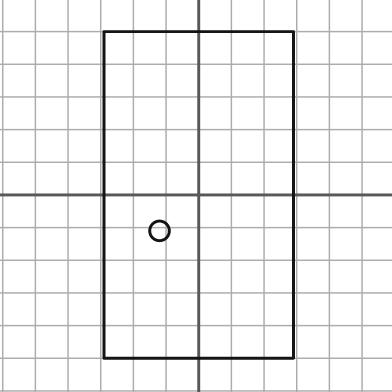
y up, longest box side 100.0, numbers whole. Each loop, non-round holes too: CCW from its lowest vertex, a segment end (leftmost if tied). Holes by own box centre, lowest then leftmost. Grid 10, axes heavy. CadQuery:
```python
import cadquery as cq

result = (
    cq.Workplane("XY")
    .moveTo(-29.0, -50.0)
    .lineTo(29.0, -50.0)
    .lineTo(29.0, 50.0)
    .lineTo(-29.0, 50.0)
    .close()
    .moveTo(-12.0, -11.0)
    .circle(3.0)
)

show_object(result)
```